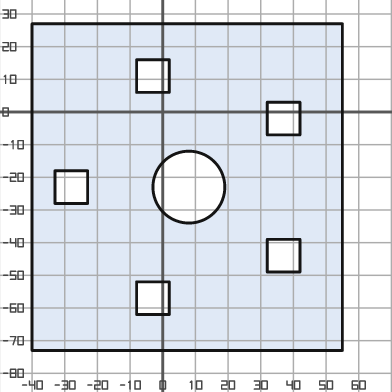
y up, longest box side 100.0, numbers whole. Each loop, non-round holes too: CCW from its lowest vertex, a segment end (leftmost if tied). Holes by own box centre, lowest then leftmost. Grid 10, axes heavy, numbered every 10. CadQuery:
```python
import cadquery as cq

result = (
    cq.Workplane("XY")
    .moveTo(-40.0, -73.0)
    .lineTo(55.0, -73.0)
    .lineTo(55.0, 27.0)
    .lineTo(-40.0, 27.0)
    .close()
    .moveTo(-8.0, -62.0)
    .lineTo(2.0, -62.0)
    .lineTo(2.0, -52.0)
    .lineTo(-8.0, -52.0)
    .close()
    .moveTo(32.0, -49.0)
    .lineTo(42.0, -49.0)
    .lineTo(42.0, -39.0)
    .lineTo(32.0, -39.0)
    .close()
    .moveTo(-33.0, -28.0)
    .lineTo(-23.0, -28.0)
    .lineTo(-23.0, -18.0)
    .lineTo(-33.0, -18.0)
    .close()
    .moveTo(8.0, -23.0)
    .circle(11.0)
    .moveTo(32.0, -7.0)
    .lineTo(42.0, -7.0)
    .lineTo(42.0, 3.0)
    .lineTo(32.0, 3.0)
    .close()
    .moveTo(-8.0, 6.0)
    .lineTo(2.0, 6.0)
    .lineTo(2.0, 16.0)
    .lineTo(-8.0, 16.0)
    .close()
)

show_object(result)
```